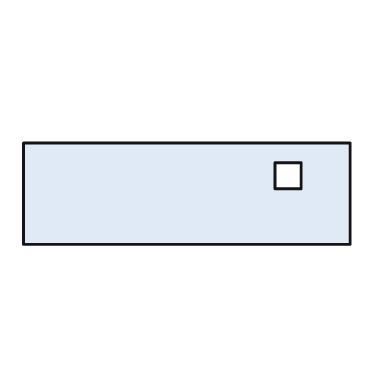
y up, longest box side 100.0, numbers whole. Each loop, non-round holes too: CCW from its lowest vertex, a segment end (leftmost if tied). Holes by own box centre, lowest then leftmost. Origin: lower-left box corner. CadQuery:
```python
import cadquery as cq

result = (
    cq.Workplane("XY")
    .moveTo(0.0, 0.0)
    .lineTo(100.0, 0.0)
    .lineTo(100.0, 31.0)
    .lineTo(0.0, 31.0)
    .close()
    .moveTo(77.0, 17.0)
    .lineTo(85.0, 17.0)
    .lineTo(85.0, 25.0)
    .lineTo(77.0, 25.0)
    .close()
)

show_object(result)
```